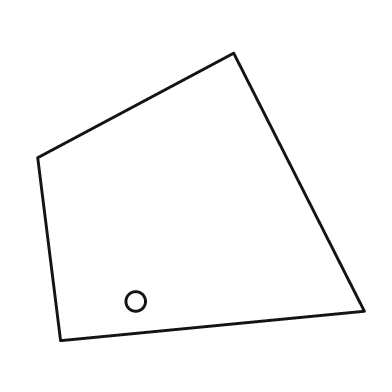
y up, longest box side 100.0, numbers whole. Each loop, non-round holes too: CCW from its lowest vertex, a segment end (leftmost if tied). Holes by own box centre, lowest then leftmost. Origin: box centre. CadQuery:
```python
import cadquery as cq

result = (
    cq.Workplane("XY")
    .moveTo(-43.0, -44.0)
    .lineTo(50.0, -35.0)
    .lineTo(10.0, 44.0)
    .lineTo(-50.0, 12.0)
    .close()
    .moveTo(-20.0, -32.0)
    .circle(3.0)
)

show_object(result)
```